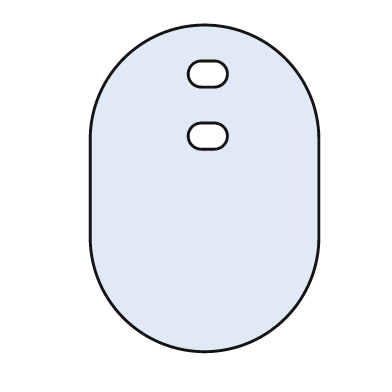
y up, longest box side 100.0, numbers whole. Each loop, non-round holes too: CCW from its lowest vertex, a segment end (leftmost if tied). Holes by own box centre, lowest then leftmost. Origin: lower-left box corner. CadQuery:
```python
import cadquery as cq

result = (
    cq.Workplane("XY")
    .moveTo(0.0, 35.0)
    .threePointArc((35.0, 0.0), (70.0, 35.0))
    .lineTo(70.0, 65.0)
    .threePointArc((35.0, 100.0), (0.0, 65.0))
    .close()
    .moveTo(34.0, 62.0)
    .lineTo(38.0, 62.0)
    .threePointArc((42.0, 66.0), (38.0, 70.0))
    .lineTo(34.0, 70.0)
    .threePointArc((30.0, 66.0), (34.0, 62.0))
    .close()
    .moveTo(34.0, 81.0)
    .lineTo(38.0, 81.0)
    .threePointArc((42.0, 85.0), (38.0, 89.0))
    .lineTo(34.0, 89.0)
    .threePointArc((30.0, 85.0), (34.0, 81.0))
    .close()
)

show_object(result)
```